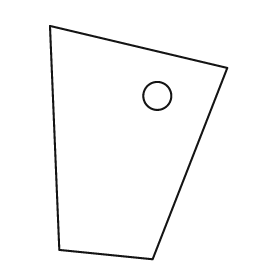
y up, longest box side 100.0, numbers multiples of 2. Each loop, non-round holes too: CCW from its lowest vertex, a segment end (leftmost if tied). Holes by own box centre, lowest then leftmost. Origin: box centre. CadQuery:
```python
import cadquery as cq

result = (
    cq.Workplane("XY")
    .moveTo(6.0, -50.0)
    .lineTo(38.0, 32.0)
    .lineTo(-38.0, 50.0)
    .lineTo(-34.0, -46.0)
    .close()
    .moveTo(8.0, 20.0)
    .circle(6.0)
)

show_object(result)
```